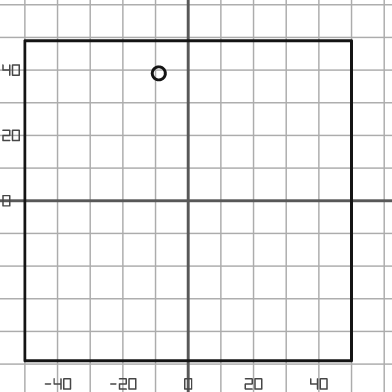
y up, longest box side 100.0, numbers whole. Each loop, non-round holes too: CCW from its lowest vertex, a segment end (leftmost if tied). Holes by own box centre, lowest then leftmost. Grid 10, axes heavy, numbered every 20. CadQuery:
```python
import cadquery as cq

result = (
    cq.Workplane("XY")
    .moveTo(-50.0, -49.0)
    .lineTo(50.0, -49.0)
    .lineTo(50.0, 49.0)
    .lineTo(-50.0, 49.0)
    .close()
    .moveTo(-9.0, 39.0)
    .circle(2.0)
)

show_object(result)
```